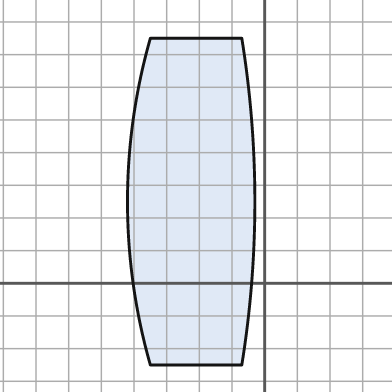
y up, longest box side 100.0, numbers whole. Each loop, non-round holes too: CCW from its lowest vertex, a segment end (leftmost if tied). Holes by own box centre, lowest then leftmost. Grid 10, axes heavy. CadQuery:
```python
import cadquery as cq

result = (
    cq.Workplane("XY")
    .moveTo(-35.0, -25.0)
    .lineTo(-7.0, -25.0)
    .threePointArc((-3.0, 25.0), (-7.0, 75.0))
    .lineTo(-35.0, 75.0)
    .threePointArc((-42.0, 25.0), (-35.0, -25.0))
    .close()
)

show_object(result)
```